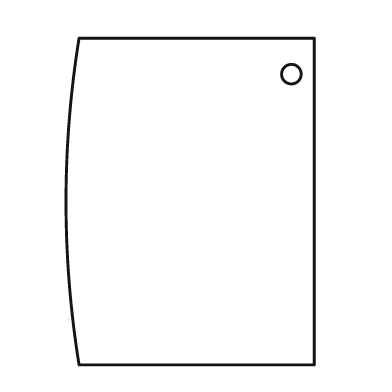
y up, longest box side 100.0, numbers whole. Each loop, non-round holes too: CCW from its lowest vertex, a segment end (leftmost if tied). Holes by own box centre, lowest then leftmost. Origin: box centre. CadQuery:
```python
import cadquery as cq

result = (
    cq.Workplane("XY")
    .moveTo(-34.0, -50.0)
    .lineTo(38.0, -50.0)
    .lineTo(38.0, 50.0)
    .lineTo(-34.0, 50.0)
    .threePointArc((-38.0, 0.0), (-34.0, -50.0))
    .close()
    .moveTo(31.0, 39.0)
    .circle(3.0)
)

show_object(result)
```